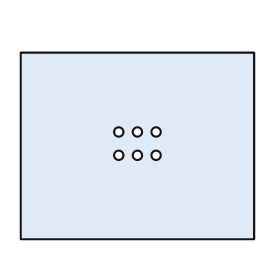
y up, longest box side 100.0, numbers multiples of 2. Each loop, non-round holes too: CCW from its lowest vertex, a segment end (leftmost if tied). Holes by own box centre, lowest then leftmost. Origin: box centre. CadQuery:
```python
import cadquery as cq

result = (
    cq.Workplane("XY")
    .moveTo(-50.0, -40.0)
    .lineTo(50.0, -40.0)
    .lineTo(50.0, 40.0)
    .lineTo(-50.0, 40.0)
    .close()
    .moveTo(-8.0, -4.0)
    .circle(2.0)
    .moveTo(0.0, -4.0)
    .circle(2.0)
    .moveTo(8.0, -4.0)
    .circle(2.0)
    .moveTo(-8.0, 6.0)
    .circle(2.0)
    .moveTo(0.0, 6.0)
    .circle(2.0)
    .moveTo(8.0, 6.0)
    .circle(2.0)
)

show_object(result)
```